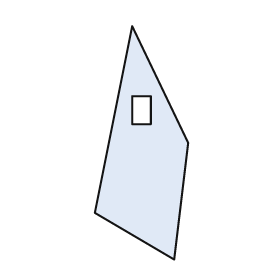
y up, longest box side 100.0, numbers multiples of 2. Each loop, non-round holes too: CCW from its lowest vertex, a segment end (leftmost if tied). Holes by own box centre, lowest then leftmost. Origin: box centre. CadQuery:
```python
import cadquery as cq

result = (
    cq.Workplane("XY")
    .moveTo(14.0, -50.0)
    .lineTo(20.0, 0.0)
    .lineTo(-4.0, 50.0)
    .lineTo(-20.0, -30.0)
    .close()
    .moveTo(-4.0, 8.0)
    .lineTo(4.0, 8.0)
    .lineTo(4.0, 20.0)
    .lineTo(-4.0, 20.0)
    .close()
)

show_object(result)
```